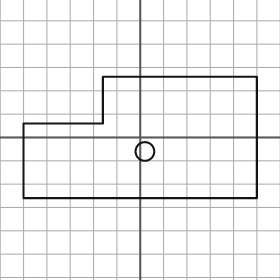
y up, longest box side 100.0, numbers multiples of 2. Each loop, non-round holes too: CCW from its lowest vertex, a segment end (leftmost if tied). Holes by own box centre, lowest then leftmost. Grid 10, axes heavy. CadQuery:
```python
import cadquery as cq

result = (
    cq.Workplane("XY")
    .moveTo(-50.0, -26.0)
    .lineTo(50.0, -26.0)
    .lineTo(50.0, 26.0)
    .lineTo(-16.0, 26.0)
    .lineTo(-16.0, 6.0)
    .lineTo(-50.0, 6.0)
    .close()
    .moveTo(2.0, -6.0)
    .circle(4.0)
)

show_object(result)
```